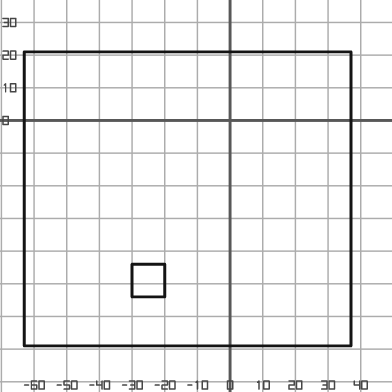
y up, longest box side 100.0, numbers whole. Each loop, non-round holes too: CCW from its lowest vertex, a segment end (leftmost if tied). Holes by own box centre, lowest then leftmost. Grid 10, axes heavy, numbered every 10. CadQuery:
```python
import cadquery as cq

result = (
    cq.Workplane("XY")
    .moveTo(-63.0, -69.0)
    .lineTo(37.0, -69.0)
    .lineTo(37.0, 21.0)
    .lineTo(-63.0, 21.0)
    .close()
    .moveTo(-30.0, -54.0)
    .lineTo(-20.0, -54.0)
    .lineTo(-20.0, -44.0)
    .lineTo(-30.0, -44.0)
    .close()
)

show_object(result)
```